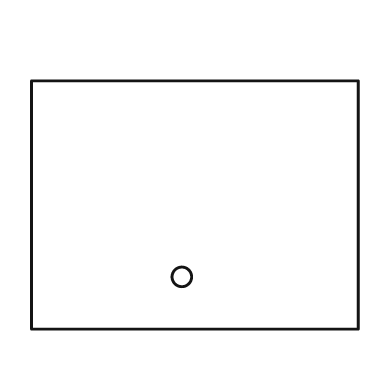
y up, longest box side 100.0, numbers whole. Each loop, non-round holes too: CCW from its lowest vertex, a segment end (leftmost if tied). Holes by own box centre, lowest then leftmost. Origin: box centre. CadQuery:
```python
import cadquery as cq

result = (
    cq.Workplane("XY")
    .moveTo(-50.0, -38.0)
    .lineTo(50.0, -38.0)
    .lineTo(50.0, 38.0)
    .lineTo(-50.0, 38.0)
    .close()
    .moveTo(-4.0, -22.0)
    .circle(3.0)
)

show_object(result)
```